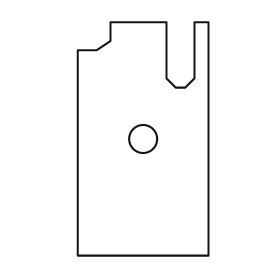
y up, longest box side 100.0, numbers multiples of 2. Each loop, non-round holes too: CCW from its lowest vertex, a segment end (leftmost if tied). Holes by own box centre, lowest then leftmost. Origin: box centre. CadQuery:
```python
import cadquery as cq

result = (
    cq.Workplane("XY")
    .moveTo(-28.0, -50.0)
    .lineTo(28.0, -50.0)
    .lineTo(28.0, 50.0)
    .lineTo(22.0, 50.0)
    .lineTo(22.0, 26.0)
    .lineTo(18.0, 22.0)
    .lineTo(14.0, 22.0)
    .lineTo(10.0, 26.0)
    .lineTo(10.0, 50.0)
    .lineTo(-14.0, 50.0)
    .lineTo(-14.0, 42.0)
    .lineTo(-20.0, 38.0)
    .lineTo(-28.0, 38.0)
    .close()
    .moveTo(0.0, 0.0)
    .circle(6.0)
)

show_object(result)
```